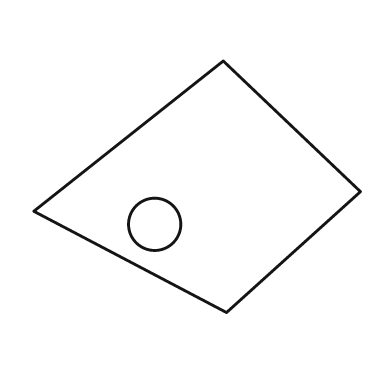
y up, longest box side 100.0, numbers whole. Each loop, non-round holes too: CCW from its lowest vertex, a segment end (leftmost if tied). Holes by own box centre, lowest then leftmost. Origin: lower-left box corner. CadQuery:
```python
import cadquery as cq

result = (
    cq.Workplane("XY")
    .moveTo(59.0, 0.0)
    .lineTo(100.0, 37.0)
    .lineTo(58.0, 77.0)
    .lineTo(0.0, 31.0)
    .close()
    .moveTo(37.0, 27.0)
    .circle(8.0)
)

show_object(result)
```